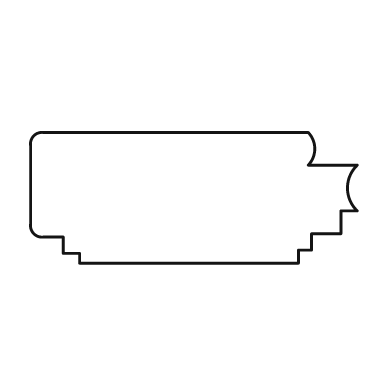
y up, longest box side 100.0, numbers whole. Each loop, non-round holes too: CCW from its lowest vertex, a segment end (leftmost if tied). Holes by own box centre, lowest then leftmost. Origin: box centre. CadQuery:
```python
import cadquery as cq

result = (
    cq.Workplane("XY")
    .moveTo(-35.0, -20.0)
    .lineTo(32.0, -20.0)
    .lineTo(32.0, -16.0)
    .lineTo(36.0, -16.0)
    .lineTo(36.0, -11.0)
    .lineTo(45.0, -11.0)
    .lineTo(45.0, -4.0)
    .lineTo(50.0, -4.0)
    .threePointArc((47.0, 3.0), (50.0, 10.0))
    .lineTo(35.0, 10.0)
    .threePointArc((37.0, 15.0), (35.0, 20.0))
    .lineTo(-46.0, 20.0)
    .threePointArc((-49.0, 19.0), (-50.0, 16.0))
    .lineTo(-50.0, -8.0)
    .threePointArc((-49.0, -11.0), (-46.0, -12.0))
    .lineTo(-40.0, -12.0)
    .lineTo(-40.0, -17.0)
    .lineTo(-35.0, -17.0)
    .close()
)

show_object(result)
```